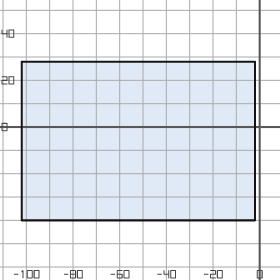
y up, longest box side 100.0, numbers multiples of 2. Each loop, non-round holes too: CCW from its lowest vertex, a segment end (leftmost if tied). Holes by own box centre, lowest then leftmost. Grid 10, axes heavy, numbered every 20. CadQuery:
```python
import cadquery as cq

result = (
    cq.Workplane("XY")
    .moveTo(-102.0, -40.0)
    .lineTo(-2.0, -40.0)
    .lineTo(-2.0, 28.0)
    .lineTo(-102.0, 28.0)
    .close()
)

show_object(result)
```